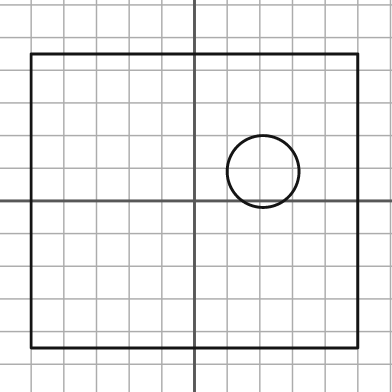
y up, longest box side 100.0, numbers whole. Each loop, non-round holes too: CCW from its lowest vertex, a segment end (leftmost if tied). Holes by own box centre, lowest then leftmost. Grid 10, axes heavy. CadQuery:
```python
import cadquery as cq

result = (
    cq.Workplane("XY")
    .moveTo(-50.0, -45.0)
    .lineTo(50.0, -45.0)
    .lineTo(50.0, 45.0)
    .lineTo(-50.0, 45.0)
    .close()
    .moveTo(21.0, 9.0)
    .circle(11.0)
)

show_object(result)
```